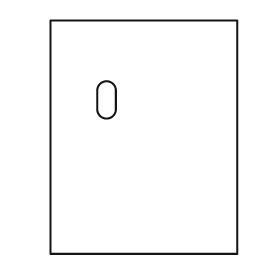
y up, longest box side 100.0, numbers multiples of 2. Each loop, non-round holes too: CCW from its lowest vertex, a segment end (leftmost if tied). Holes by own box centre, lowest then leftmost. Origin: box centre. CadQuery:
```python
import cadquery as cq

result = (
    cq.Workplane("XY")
    .moveTo(-40.0, -50.0)
    .lineTo(40.0, -50.0)
    .lineTo(40.0, 50.0)
    .lineTo(-40.0, 50.0)
    .close()
    .moveTo(-20.0, 12.0)
    .threePointArc((-16.0, 8.0), (-12.0, 12.0))
    .lineTo(-12.0, 20.0)
    .threePointArc((-16.0, 24.0), (-20.0, 20.0))
    .close()
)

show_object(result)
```